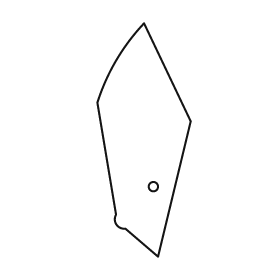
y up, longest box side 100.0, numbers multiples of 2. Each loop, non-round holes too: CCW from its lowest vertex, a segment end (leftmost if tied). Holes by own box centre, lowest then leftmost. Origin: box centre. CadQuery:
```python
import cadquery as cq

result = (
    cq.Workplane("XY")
    .moveTo(6.0, -50.0)
    .lineTo(20.0, 8.0)
    .lineTo(0.0, 50.0)
    .threePointArc((-12.0, 34.0), (-20.0, 16.0))
    .lineTo(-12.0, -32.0)
    .threePointArc((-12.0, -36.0), (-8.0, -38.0))
    .close()
    .moveTo(4.0, -20.0)
    .circle(2.0)
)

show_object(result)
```